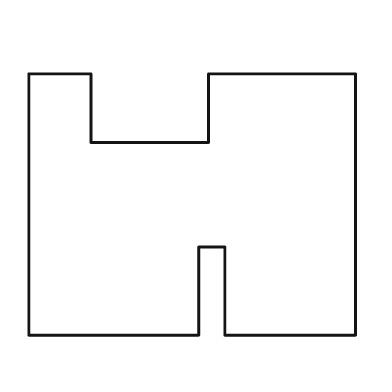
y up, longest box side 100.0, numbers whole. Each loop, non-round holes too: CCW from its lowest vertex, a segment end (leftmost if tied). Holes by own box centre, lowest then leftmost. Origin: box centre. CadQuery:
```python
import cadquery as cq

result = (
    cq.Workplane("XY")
    .moveTo(-50.0, -40.0)
    .lineTo(2.0, -40.0)
    .lineTo(2.0, -13.0)
    .lineTo(10.0, -13.0)
    .lineTo(10.0, -40.0)
    .lineTo(50.0, -40.0)
    .lineTo(50.0, 40.0)
    .lineTo(5.0, 40.0)
    .lineTo(5.0, 19.0)
    .lineTo(-31.0, 19.0)
    .lineTo(-31.0, 40.0)
    .lineTo(-50.0, 40.0)
    .close()
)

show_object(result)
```